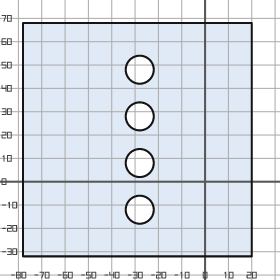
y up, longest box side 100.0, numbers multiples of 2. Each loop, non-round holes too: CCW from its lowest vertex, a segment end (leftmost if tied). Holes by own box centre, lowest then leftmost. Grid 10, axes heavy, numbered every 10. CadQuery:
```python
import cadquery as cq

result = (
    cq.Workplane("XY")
    .moveTo(-78.0, -32.0)
    .lineTo(20.0, -32.0)
    .lineTo(20.0, 68.0)
    .lineTo(-78.0, 68.0)
    .close()
    .moveTo(-28.0, -12.0)
    .circle(6.0)
    .moveTo(-28.0, 8.0)
    .circle(6.0)
    .moveTo(-28.0, 28.0)
    .circle(6.0)
    .moveTo(-28.0, 48.0)
    .circle(6.0)
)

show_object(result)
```